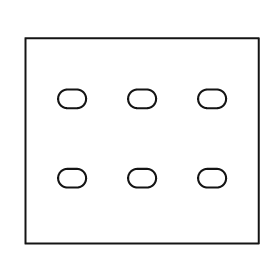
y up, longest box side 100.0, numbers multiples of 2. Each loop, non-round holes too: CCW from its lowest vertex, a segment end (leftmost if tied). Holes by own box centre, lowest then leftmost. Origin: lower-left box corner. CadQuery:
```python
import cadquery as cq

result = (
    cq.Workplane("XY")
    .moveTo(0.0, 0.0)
    .lineTo(100.0, 0.0)
    .lineTo(100.0, 88.0)
    .lineTo(0.0, 88.0)
    .close()
    .moveTo(18.0, 24.0)
    .lineTo(22.0, 24.0)
    .threePointArc((26.0, 28.0), (22.0, 32.0))
    .lineTo(18.0, 32.0)
    .threePointArc((14.0, 28.0), (18.0, 24.0))
    .close()
    .moveTo(48.0, 24.0)
    .lineTo(52.0, 24.0)
    .threePointArc((56.0, 28.0), (52.0, 32.0))
    .lineTo(48.0, 32.0)
    .threePointArc((44.0, 28.0), (48.0, 24.0))
    .close()
    .moveTo(78.0, 24.0)
    .lineTo(82.0, 24.0)
    .threePointArc((86.0, 28.0), (82.0, 32.0))
    .lineTo(78.0, 32.0)
    .threePointArc((74.0, 28.0), (78.0, 24.0))
    .close()
    .moveTo(18.0, 58.0)
    .lineTo(22.0, 58.0)
    .threePointArc((26.0, 62.0), (22.0, 66.0))
    .lineTo(18.0, 66.0)
    .threePointArc((14.0, 62.0), (18.0, 58.0))
    .close()
    .moveTo(48.0, 58.0)
    .lineTo(52.0, 58.0)
    .threePointArc((56.0, 62.0), (52.0, 66.0))
    .lineTo(48.0, 66.0)
    .threePointArc((44.0, 62.0), (48.0, 58.0))
    .close()
    .moveTo(78.0, 58.0)
    .lineTo(82.0, 58.0)
    .threePointArc((86.0, 62.0), (82.0, 66.0))
    .lineTo(78.0, 66.0)
    .threePointArc((74.0, 62.0), (78.0, 58.0))
    .close()
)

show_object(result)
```